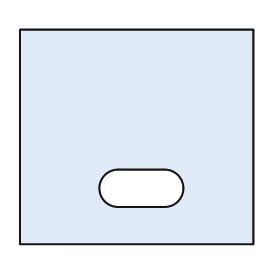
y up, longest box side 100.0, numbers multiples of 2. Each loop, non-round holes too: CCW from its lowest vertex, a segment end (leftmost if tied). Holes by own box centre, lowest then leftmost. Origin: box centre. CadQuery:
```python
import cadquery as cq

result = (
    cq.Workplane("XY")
    .moveTo(-50.0, -46.0)
    .lineTo(50.0, -46.0)
    .lineTo(50.0, 46.0)
    .lineTo(-50.0, 46.0)
    .close()
    .moveTo(-8.0, -30.0)
    .lineTo(12.0, -30.0)
    .threePointArc((20.0, -22.0), (12.0, -14.0))
    .lineTo(-8.0, -14.0)
    .threePointArc((-16.0, -22.0), (-8.0, -30.0))
    .close()
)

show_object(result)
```